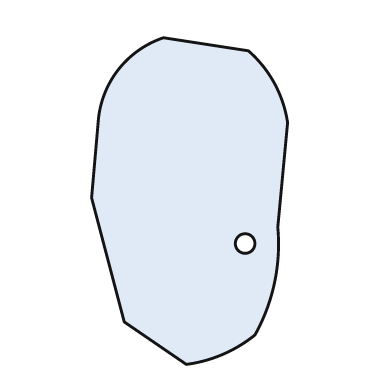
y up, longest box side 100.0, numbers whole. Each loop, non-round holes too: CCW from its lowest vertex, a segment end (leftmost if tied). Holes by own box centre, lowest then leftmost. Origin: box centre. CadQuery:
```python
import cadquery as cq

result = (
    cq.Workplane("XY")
    .moveTo(-1.0, -50.0)
    .threePointArc((10.0, -47.0), (20.0, -41.0))
    .threePointArc((26.0, -25.0), (27.0, -8.0))
    .lineTo(30.0, 24.0)
    .threePointArc((26.0, 36.0), (18.0, 46.0))
    .lineTo(-8.0, 50.0)
    .threePointArc((-22.0, 40.0), (-28.0, 24.0))
    .lineTo(-30.0, 1.0)
    .lineTo(-20.0, -37.0)
    .close()
    .moveTo(17.0, -13.0)
    .circle(3.0)
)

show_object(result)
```